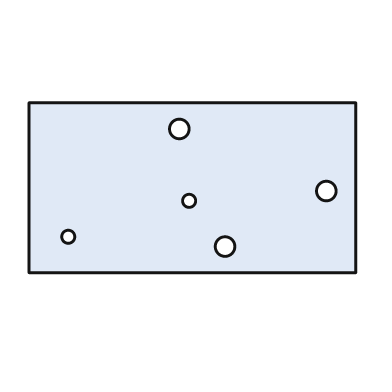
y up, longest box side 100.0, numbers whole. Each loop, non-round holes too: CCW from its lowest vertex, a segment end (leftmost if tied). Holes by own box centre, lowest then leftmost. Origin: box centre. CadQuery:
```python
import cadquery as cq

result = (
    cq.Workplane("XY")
    .moveTo(-50.0, -26.0)
    .lineTo(50.0, -26.0)
    .lineTo(50.0, 26.0)
    .lineTo(-50.0, 26.0)
    .close()
    .moveTo(10.0, -18.0)
    .circle(3.0)
    .moveTo(-38.0, -15.0)
    .circle(2.0)
    .moveTo(-1.0, -4.0)
    .circle(2.0)
    .moveTo(41.0, -1.0)
    .circle(3.0)
    .moveTo(-4.0, 18.0)
    .circle(3.0)
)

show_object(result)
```